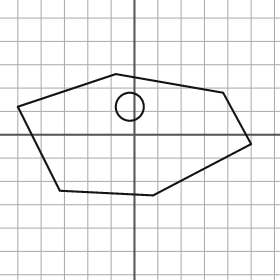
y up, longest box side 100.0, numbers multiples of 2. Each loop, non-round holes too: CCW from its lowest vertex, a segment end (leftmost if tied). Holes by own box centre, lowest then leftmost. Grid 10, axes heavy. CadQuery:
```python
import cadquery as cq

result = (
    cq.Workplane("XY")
    .moveTo(8.0, -26.0)
    .lineTo(50.0, -4.0)
    .lineTo(38.0, 18.0)
    .lineTo(-8.0, 26.0)
    .lineTo(-50.0, 12.0)
    .lineTo(-32.0, -24.0)
    .close()
    .moveTo(-2.0, 12.0)
    .circle(6.0)
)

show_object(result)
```